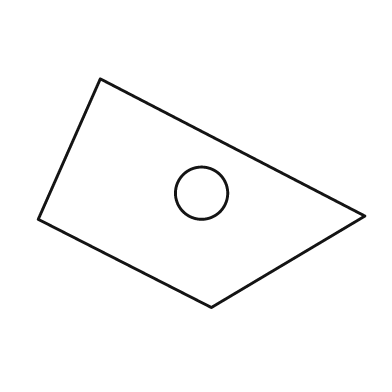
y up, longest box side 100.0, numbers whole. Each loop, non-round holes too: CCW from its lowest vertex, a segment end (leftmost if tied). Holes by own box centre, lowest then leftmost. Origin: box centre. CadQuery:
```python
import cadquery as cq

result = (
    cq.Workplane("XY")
    .moveTo(3.0, -35.0)
    .lineTo(50.0, -7.0)
    .lineTo(-31.0, 35.0)
    .lineTo(-50.0, -8.0)
    .close()
    .moveTo(0.0, 0.0)
    .circle(8.0)
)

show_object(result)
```